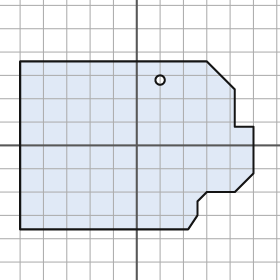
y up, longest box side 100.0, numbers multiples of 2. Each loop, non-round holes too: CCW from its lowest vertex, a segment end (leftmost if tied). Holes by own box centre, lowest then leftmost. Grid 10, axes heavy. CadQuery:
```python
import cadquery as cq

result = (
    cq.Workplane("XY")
    .moveTo(-50.0, -36.0)
    .lineTo(22.0, -36.0)
    .lineTo(26.0, -30.0)
    .lineTo(26.0, -24.0)
    .lineTo(30.0, -20.0)
    .lineTo(42.0, -20.0)
    .lineTo(50.0, -12.0)
    .lineTo(50.0, 8.0)
    .lineTo(42.0, 8.0)
    .lineTo(42.0, 24.0)
    .lineTo(30.0, 36.0)
    .lineTo(-50.0, 36.0)
    .close()
    .moveTo(10.0, 28.0)
    .circle(2.0)
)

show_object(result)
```